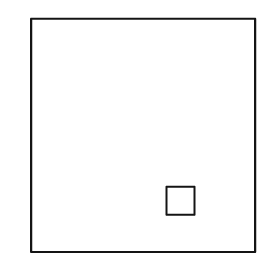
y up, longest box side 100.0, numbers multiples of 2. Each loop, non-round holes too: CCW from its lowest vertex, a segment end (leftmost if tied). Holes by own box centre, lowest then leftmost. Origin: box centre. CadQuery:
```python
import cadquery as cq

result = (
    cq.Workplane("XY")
    .moveTo(-48.0, -50.0)
    .lineTo(48.0, -50.0)
    .lineTo(48.0, 50.0)
    .lineTo(-48.0, 50.0)
    .close()
    .moveTo(10.0, -34.0)
    .lineTo(22.0, -34.0)
    .lineTo(22.0, -22.0)
    .lineTo(10.0, -22.0)
    .close()
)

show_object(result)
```